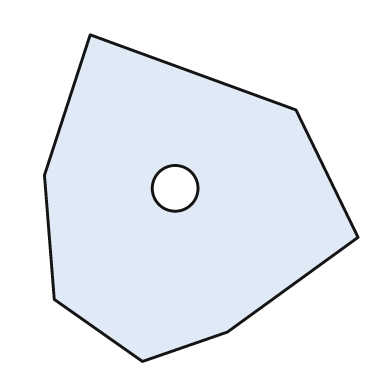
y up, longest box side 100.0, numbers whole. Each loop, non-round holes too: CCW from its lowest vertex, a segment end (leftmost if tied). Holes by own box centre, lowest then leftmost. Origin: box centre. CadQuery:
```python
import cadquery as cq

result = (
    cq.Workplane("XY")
    .moveTo(-18.0, -50.0)
    .lineTo(8.0, -41.0)
    .lineTo(48.0, -12.0)
    .lineTo(29.0, 27.0)
    .lineTo(-34.0, 50.0)
    .lineTo(-48.0, 7.0)
    .lineTo(-45.0, -31.0)
    .close()
    .moveTo(-8.0, 3.0)
    .circle(7.0)
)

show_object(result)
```